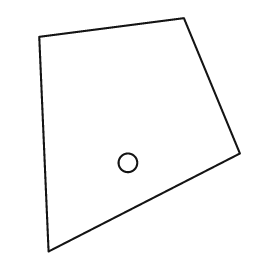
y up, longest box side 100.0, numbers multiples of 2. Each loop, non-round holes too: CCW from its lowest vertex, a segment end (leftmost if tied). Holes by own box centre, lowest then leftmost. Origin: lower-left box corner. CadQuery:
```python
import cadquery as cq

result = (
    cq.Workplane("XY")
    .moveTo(4.0, 0.0)
    .lineTo(86.0, 42.0)
    .lineTo(62.0, 100.0)
    .lineTo(0.0, 92.0)
    .close()
    .moveTo(38.0, 38.0)
    .circle(4.0)
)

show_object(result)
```